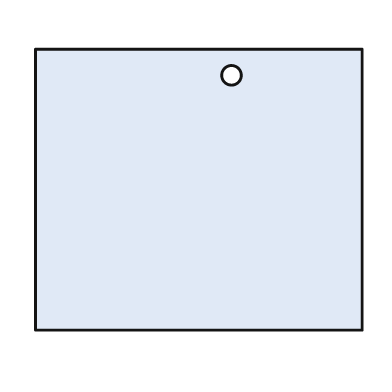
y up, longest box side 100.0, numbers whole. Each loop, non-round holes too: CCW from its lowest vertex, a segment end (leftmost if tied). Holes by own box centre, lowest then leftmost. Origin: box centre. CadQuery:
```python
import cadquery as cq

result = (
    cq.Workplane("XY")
    .moveTo(-50.0, -43.0)
    .lineTo(50.0, -43.0)
    .lineTo(50.0, 43.0)
    .lineTo(-50.0, 43.0)
    .close()
    .moveTo(10.0, 35.0)
    .circle(3.0)
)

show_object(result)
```